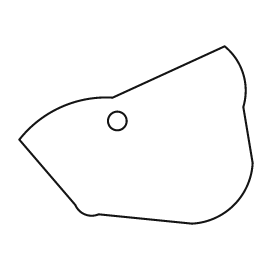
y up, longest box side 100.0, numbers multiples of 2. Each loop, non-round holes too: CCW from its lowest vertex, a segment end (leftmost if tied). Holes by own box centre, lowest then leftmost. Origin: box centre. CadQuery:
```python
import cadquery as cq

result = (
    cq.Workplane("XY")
    .moveTo(24.0, -38.0)
    .threePointArc((42.0, -30.0), (50.0, -12.0))
    .lineTo(46.0, 12.0)
    .threePointArc((46.0, 26.0), (38.0, 38.0))
    .lineTo(-10.0, 16.0)
    .threePointArc((-32.0, 12.0), (-50.0, -2.0))
    .lineTo(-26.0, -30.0)
    .threePointArc((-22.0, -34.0), (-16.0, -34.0))
    .close()
    .moveTo(-8.0, 6.0)
    .circle(4.0)
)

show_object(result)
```